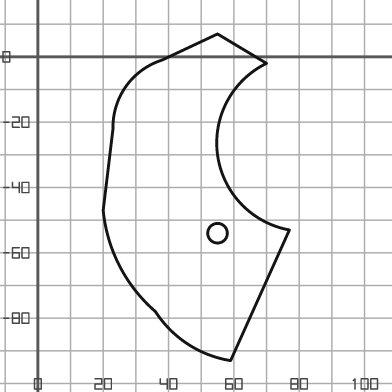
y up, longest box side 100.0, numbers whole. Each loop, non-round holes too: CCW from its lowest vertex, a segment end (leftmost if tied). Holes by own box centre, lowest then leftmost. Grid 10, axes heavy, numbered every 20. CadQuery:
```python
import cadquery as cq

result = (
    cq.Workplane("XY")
    .moveTo(59.0, -93.0)
    .lineTo(77.0, -53.0)
    .threePointArc((55.0, -30.0), (70.0, -2.0))
    .lineTo(55.0, 7.0)
    .lineTo(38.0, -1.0)
    .threePointArc((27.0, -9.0), (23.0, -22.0))
    .lineTo(20.0, -47.0)
    .threePointArc((25.0, -64.0), (36.0, -78.0))
    .threePointArc((46.0, -88.0), (59.0, -93.0))
    .close()
    .moveTo(55.0, -54.0)
    .circle(3.0)
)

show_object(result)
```